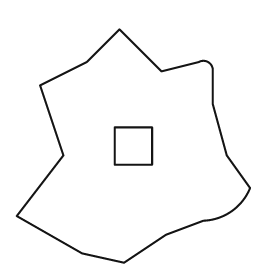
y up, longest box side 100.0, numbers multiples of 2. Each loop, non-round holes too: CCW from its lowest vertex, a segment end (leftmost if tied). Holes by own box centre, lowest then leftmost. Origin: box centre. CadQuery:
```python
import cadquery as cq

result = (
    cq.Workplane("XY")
    .moveTo(-4.0, -50.0)
    .lineTo(14.0, -38.0)
    .lineTo(30.0, -32.0)
    .threePointArc((42.0, -28.0), (50.0, -18.0))
    .lineTo(40.0, -4.0)
    .lineTo(34.0, 18.0)
    .lineTo(34.0, 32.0)
    .threePointArc((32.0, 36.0), (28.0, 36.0))
    .lineTo(12.0, 32.0)
    .lineTo(-6.0, 50.0)
    .lineTo(-20.0, 36.0)
    .lineTo(-40.0, 26.0)
    .lineTo(-30.0, -4.0)
    .lineTo(-50.0, -30.0)
    .lineTo(-22.0, -46.0)
    .close()
    .moveTo(-8.0, -8.0)
    .lineTo(8.0, -8.0)
    .lineTo(8.0, 8.0)
    .lineTo(-8.0, 8.0)
    .close()
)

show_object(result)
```